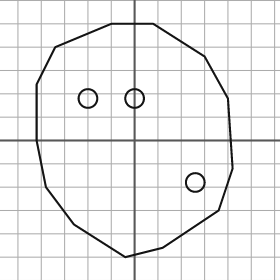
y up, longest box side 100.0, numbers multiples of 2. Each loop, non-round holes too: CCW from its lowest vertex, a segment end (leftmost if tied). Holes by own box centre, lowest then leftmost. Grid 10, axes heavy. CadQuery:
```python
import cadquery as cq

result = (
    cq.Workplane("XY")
    .moveTo(-4.0, -50.0)
    .lineTo(12.0, -46.0)
    .lineTo(36.0, -30.0)
    .lineTo(42.0, -12.0)
    .lineTo(40.0, 18.0)
    .lineTo(30.0, 36.0)
    .lineTo(8.0, 50.0)
    .lineTo(-10.0, 50.0)
    .lineTo(-34.0, 40.0)
    .lineTo(-42.0, 24.0)
    .lineTo(-42.0, 0.0)
    .lineTo(-38.0, -20.0)
    .lineTo(-26.0, -36.0)
    .close()
    .moveTo(26.0, -18.0)
    .circle(4.0)
    .moveTo(-20.0, 18.0)
    .circle(4.0)
    .moveTo(0.0, 18.0)
    .circle(4.0)
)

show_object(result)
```